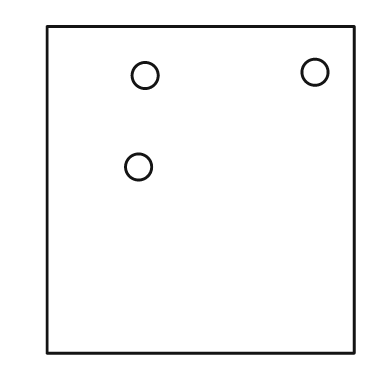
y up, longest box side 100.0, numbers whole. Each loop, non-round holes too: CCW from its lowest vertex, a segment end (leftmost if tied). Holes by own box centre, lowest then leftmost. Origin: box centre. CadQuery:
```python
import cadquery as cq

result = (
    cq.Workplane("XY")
    .moveTo(-47.0, -50.0)
    .lineTo(47.0, -50.0)
    .lineTo(47.0, 50.0)
    .lineTo(-47.0, 50.0)
    .close()
    .moveTo(-19.0, 7.0)
    .circle(4.0)
    .moveTo(-17.0, 35.0)
    .circle(4.0)
    .moveTo(35.0, 36.0)
    .circle(4.0)
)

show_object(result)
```